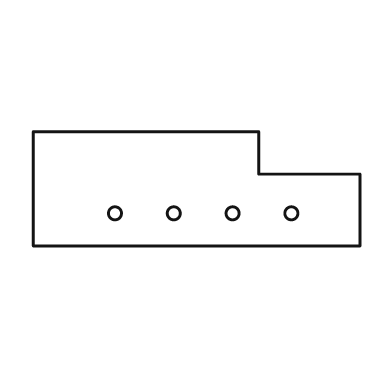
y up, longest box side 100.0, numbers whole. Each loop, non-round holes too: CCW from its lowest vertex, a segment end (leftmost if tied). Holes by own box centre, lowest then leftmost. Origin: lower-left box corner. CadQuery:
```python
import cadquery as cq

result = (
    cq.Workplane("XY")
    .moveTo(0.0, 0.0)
    .lineTo(100.0, 0.0)
    .lineTo(100.0, 22.0)
    .lineTo(69.0, 22.0)
    .lineTo(69.0, 35.0)
    .lineTo(0.0, 35.0)
    .close()
    .moveTo(25.0, 10.0)
    .circle(2.0)
    .moveTo(43.0, 10.0)
    .circle(2.0)
    .moveTo(61.0, 10.0)
    .circle(2.0)
    .moveTo(79.0, 10.0)
    .circle(2.0)
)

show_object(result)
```